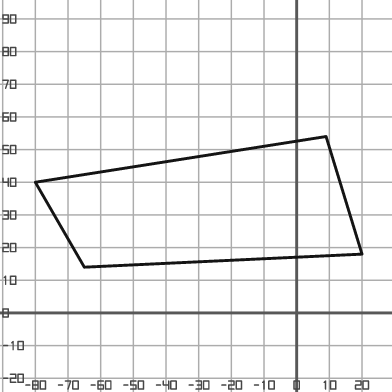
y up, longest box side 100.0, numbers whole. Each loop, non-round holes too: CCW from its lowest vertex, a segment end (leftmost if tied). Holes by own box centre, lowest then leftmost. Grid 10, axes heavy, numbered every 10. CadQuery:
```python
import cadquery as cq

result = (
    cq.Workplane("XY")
    .moveTo(-65.0, 14.0)
    .lineTo(20.0, 18.0)
    .lineTo(9.0, 54.0)
    .lineTo(-80.0, 40.0)
    .close()
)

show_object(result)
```